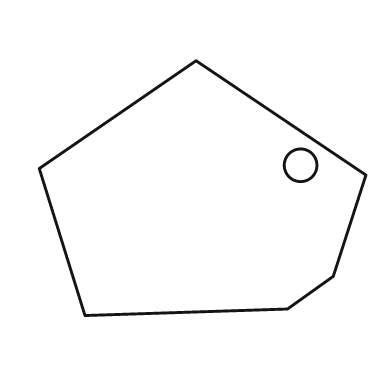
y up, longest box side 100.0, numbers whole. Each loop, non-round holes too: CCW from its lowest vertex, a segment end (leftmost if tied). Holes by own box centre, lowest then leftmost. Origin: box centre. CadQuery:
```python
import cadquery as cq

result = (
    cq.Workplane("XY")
    .moveTo(-36.0, -39.0)
    .lineTo(26.0, -37.0)
    .lineTo(40.0, -27.0)
    .lineTo(50.0, 4.0)
    .lineTo(-2.0, 39.0)
    .lineTo(-50.0, 6.0)
    .close()
    .moveTo(30.0, 7.0)
    .circle(5.0)
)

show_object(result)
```